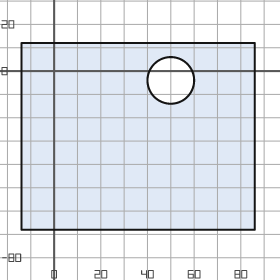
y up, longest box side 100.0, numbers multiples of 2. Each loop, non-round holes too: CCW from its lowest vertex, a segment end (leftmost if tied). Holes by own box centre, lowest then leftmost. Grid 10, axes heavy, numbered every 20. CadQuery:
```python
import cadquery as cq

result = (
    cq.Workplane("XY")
    .moveTo(-14.0, -68.0)
    .lineTo(86.0, -68.0)
    .lineTo(86.0, 12.0)
    .lineTo(-14.0, 12.0)
    .close()
    .moveTo(50.0, -4.0)
    .circle(10.0)
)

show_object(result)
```